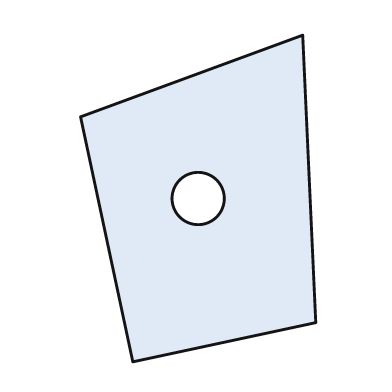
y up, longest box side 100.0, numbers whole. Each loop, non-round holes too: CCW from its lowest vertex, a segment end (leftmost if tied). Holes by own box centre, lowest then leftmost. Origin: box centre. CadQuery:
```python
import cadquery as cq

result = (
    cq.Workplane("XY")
    .moveTo(-20.0, -50.0)
    .lineTo(36.0, -38.0)
    .lineTo(32.0, 50.0)
    .lineTo(-36.0, 25.0)
    .close()
    .moveTo(0.0, 0.0)
    .circle(8.0)
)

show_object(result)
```